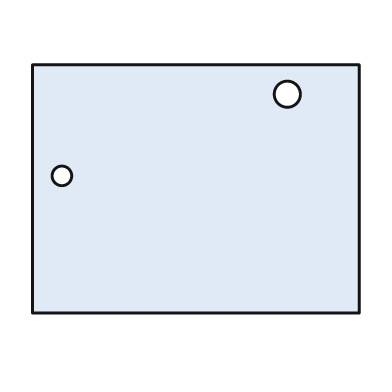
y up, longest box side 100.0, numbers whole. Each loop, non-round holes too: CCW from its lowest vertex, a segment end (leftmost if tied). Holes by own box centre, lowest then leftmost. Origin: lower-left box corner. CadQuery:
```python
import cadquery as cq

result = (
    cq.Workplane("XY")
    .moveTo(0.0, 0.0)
    .lineTo(100.0, 0.0)
    .lineTo(100.0, 76.0)
    .lineTo(0.0, 76.0)
    .close()
    .moveTo(9.0, 42.0)
    .circle(3.0)
    .moveTo(78.0, 67.0)
    .circle(4.0)
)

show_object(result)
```